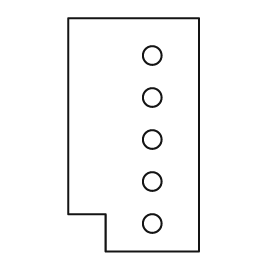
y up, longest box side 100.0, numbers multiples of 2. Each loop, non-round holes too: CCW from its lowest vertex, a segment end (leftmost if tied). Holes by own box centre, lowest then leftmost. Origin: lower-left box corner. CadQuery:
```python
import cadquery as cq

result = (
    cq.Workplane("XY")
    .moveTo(16.0, 0.0)
    .lineTo(56.0, 0.0)
    .lineTo(56.0, 100.0)
    .lineTo(0.0, 100.0)
    .lineTo(0.0, 16.0)
    .lineTo(16.0, 16.0)
    .close()
    .moveTo(36.0, 12.0)
    .circle(4.0)
    .moveTo(36.0, 30.0)
    .circle(4.0)
    .moveTo(36.0, 48.0)
    .circle(4.0)
    .moveTo(36.0, 66.0)
    .circle(4.0)
    .moveTo(36.0, 84.0)
    .circle(4.0)
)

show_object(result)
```